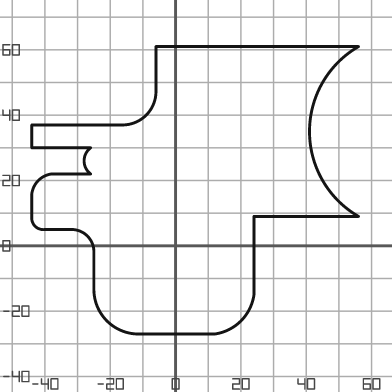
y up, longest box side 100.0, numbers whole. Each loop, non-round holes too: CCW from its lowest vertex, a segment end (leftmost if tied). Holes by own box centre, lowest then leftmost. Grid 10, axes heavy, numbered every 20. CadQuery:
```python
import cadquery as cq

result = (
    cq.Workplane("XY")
    .moveTo(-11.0, -27.0)
    .lineTo(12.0, -27.0)
    .threePointArc((20.0, -23.0), (24.0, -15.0))
    .lineTo(24.0, 9.0)
    .lineTo(56.0, 9.0)
    .threePointArc((41.0, 35.0), (56.0, 61.0))
    .lineTo(-6.0, 61.0)
    .lineTo(-6.0, 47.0)
    .threePointArc((-9.0, 40.0), (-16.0, 37.0))
    .lineTo(-44.0, 37.0)
    .lineTo(-44.0, 30.0)
    .lineTo(-26.0, 30.0)
    .threePointArc((-28.0, 26.0), (-26.0, 22.0))
    .lineTo(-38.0, 22.0)
    .threePointArc((-42.0, 20.0), (-44.0, 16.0))
    .lineTo(-44.0, 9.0)
    .threePointArc((-43.0, 6.0), (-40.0, 5.0))
    .lineTo(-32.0, 5.0)
    .threePointArc((-27.0, 3.0), (-25.0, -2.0))
    .lineTo(-25.0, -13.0)
    .threePointArc((-21.0, -23.0), (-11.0, -27.0))
    .close()
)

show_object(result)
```